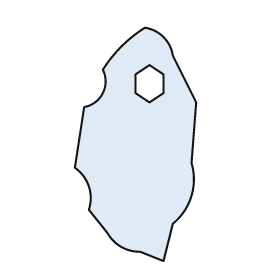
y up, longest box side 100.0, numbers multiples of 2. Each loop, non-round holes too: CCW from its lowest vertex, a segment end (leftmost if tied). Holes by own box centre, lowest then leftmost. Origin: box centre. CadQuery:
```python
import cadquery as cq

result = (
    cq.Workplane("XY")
    .moveTo(12.0, -50.0)
    .lineTo(16.0, -34.0)
    .threePointArc((24.0, -22.0), (24.0, -8.0))
    .lineTo(26.0, 18.0)
    .lineTo(16.0, 38.0)
    .threePointArc((12.0, 46.0), (4.0, 50.0))
    .threePointArc((-6.0, 42.0), (-14.0, 32.0))
    .threePointArc((-14.0, 22.0), (-22.0, 16.0))
    .lineTo(-26.0, -10.0)
    .threePointArc((-20.0, -18.0), (-20.0, -28.0))
    .lineTo(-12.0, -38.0)
    .threePointArc((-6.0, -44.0), (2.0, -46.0))
    .close()
    .moveTo(6.0, 18.0)
    .lineTo(12.0, 22.0)
    .lineTo(12.0, 30.0)
    .lineTo(6.0, 34.0)
    .lineTo(0.0, 30.0)
    .lineTo(0.0, 22.0)
    .close()
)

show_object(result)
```